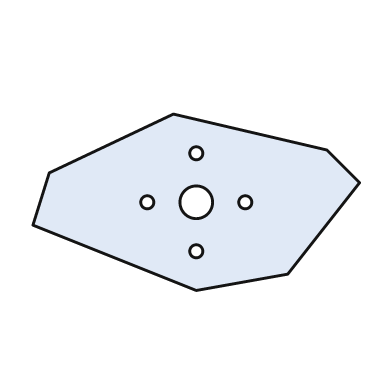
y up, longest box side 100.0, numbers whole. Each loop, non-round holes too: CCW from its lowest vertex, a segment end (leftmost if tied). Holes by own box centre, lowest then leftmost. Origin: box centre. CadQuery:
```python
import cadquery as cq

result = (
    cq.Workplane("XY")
    .moveTo(0.0, -27.0)
    .lineTo(28.0, -22.0)
    .lineTo(50.0, 6.0)
    .lineTo(40.0, 16.0)
    .lineTo(-7.0, 27.0)
    .lineTo(-45.0, 9.0)
    .lineTo(-50.0, -7.0)
    .close()
    .moveTo(0.0, -15.0)
    .circle(2.0)
    .moveTo(-15.0, 0.0)
    .circle(2.0)
    .moveTo(0.0, 0.0)
    .circle(5.0)
    .moveTo(15.0, 0.0)
    .circle(2.0)
    .moveTo(0.0, 15.0)
    .circle(2.0)
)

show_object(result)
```